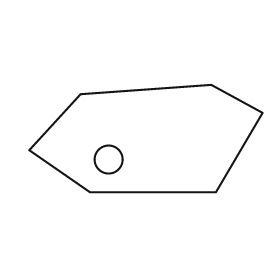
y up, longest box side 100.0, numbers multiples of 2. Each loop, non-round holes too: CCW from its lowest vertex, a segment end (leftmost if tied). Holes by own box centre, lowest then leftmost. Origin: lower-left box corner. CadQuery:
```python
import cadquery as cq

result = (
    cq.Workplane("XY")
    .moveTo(26.0, 0.0)
    .lineTo(80.0, 0.0)
    .lineTo(100.0, 34.0)
    .lineTo(78.0, 46.0)
    .lineTo(22.0, 42.0)
    .lineTo(0.0, 18.0)
    .close()
    .moveTo(34.0, 14.0)
    .circle(6.0)
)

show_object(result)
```